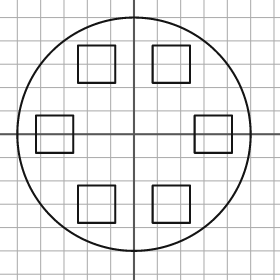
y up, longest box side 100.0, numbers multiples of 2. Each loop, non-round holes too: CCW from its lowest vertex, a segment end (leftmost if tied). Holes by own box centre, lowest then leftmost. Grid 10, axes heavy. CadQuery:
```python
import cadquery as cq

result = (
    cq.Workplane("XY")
    .moveTo(0.0, 0.0)
    .circle(50.0)
    .moveTo(-24.0, -38.0)
    .lineTo(-8.0, -38.0)
    .lineTo(-8.0, -22.0)
    .lineTo(-24.0, -22.0)
    .close()
    .moveTo(8.0, -38.0)
    .lineTo(24.0, -38.0)
    .lineTo(24.0, -22.0)
    .lineTo(8.0, -22.0)
    .close()
    .moveTo(-42.0, -8.0)
    .lineTo(-26.0, -8.0)
    .lineTo(-26.0, 8.0)
    .lineTo(-42.0, 8.0)
    .close()
    .moveTo(26.0, -8.0)
    .lineTo(42.0, -8.0)
    .lineTo(42.0, 8.0)
    .lineTo(26.0, 8.0)
    .close()
    .moveTo(-24.0, 22.0)
    .lineTo(-8.0, 22.0)
    .lineTo(-8.0, 38.0)
    .lineTo(-24.0, 38.0)
    .close()
    .moveTo(8.0, 22.0)
    .lineTo(24.0, 22.0)
    .lineTo(24.0, 38.0)
    .lineTo(8.0, 38.0)
    .close()
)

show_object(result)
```